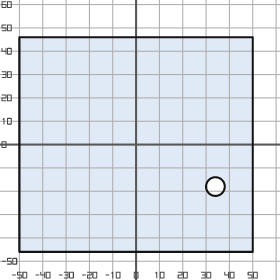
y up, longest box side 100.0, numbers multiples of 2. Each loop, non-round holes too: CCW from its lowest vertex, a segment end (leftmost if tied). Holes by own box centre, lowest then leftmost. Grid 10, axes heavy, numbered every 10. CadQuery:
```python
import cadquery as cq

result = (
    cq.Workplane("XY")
    .moveTo(-50.0, -46.0)
    .lineTo(50.0, -46.0)
    .lineTo(50.0, 46.0)
    .lineTo(-50.0, 46.0)
    .close()
    .moveTo(34.0, -18.0)
    .circle(4.0)
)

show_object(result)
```